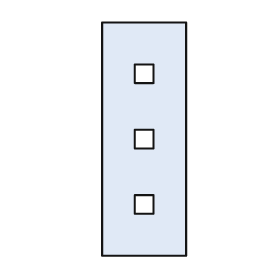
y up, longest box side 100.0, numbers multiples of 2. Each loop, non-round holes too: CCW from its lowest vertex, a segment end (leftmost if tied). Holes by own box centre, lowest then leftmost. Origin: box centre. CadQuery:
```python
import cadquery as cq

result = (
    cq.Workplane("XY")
    .moveTo(-18.0, -50.0)
    .lineTo(18.0, -50.0)
    .lineTo(18.0, 50.0)
    .lineTo(-18.0, 50.0)
    .close()
    .moveTo(-4.0, -32.0)
    .lineTo(4.0, -32.0)
    .lineTo(4.0, -24.0)
    .lineTo(-4.0, -24.0)
    .close()
    .moveTo(-4.0, -4.0)
    .lineTo(4.0, -4.0)
    .lineTo(4.0, 4.0)
    .lineTo(-4.0, 4.0)
    .close()
    .moveTo(-4.0, 24.0)
    .lineTo(4.0, 24.0)
    .lineTo(4.0, 32.0)
    .lineTo(-4.0, 32.0)
    .close()
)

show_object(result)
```